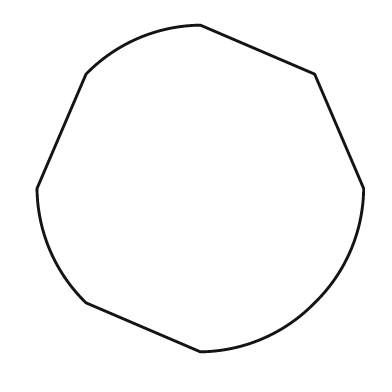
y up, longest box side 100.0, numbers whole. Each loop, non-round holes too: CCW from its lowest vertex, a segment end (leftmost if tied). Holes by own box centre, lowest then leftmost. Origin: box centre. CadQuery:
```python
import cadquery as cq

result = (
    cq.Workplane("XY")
    .moveTo(0.0, -50.0)
    .threePointArc((19.0, -46.0), (35.0, -35.0))
    .threePointArc((46.0, -19.0), (50.0, 0.0))
    .lineTo(35.0, 35.0)
    .lineTo(0.0, 50.0)
    .threePointArc((-19.0, 46.0), (-35.0, 35.0))
    .lineTo(-50.0, 0.0)
    .threePointArc((-46.0, -19.0), (-35.0, -35.0))
    .close()
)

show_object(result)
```